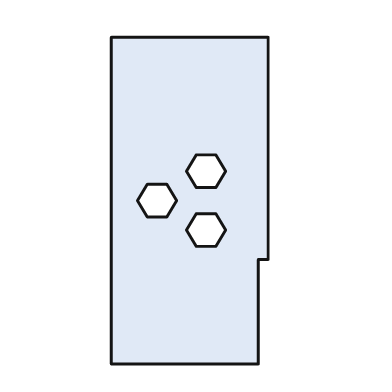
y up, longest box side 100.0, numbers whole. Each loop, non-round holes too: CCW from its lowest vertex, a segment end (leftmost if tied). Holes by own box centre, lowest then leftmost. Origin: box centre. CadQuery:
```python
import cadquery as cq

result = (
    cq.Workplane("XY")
    .moveTo(-24.0, -50.0)
    .lineTo(21.0, -50.0)
    .lineTo(21.0, -18.0)
    .lineTo(24.0, -18.0)
    .lineTo(24.0, 50.0)
    .lineTo(-24.0, 50.0)
    .close()
    .moveTo(2.0, -14.0)
    .lineTo(8.0, -14.0)
    .lineTo(11.0, -9.0)
    .lineTo(8.0, -4.0)
    .lineTo(2.0, -4.0)
    .lineTo(-1.0, -9.0)
    .close()
    .moveTo(-13.0, -5.0)
    .lineTo(-7.0, -5.0)
    .lineTo(-4.0, 0.0)
    .lineTo(-7.0, 5.0)
    .lineTo(-13.0, 5.0)
    .lineTo(-16.0, 0.0)
    .close()
    .moveTo(2.0, 4.0)
    .lineTo(8.0, 4.0)
    .lineTo(11.0, 9.0)
    .lineTo(8.0, 14.0)
    .lineTo(2.0, 14.0)
    .lineTo(-1.0, 9.0)
    .close()
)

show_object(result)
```